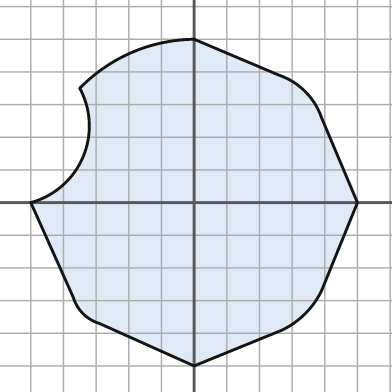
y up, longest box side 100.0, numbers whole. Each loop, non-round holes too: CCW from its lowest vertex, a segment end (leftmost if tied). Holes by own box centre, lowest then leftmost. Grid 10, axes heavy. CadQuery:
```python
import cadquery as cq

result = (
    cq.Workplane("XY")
    .moveTo(0.0, -50.0)
    .lineTo(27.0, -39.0)
    .threePointArc((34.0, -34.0), (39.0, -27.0))
    .lineTo(50.0, 0.0)
    .lineTo(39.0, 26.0)
    .threePointArc((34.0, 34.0), (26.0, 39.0))
    .lineTo(0.0, 50.0)
    .threePointArc((-19.0, 46.0), (-35.0, 35.0))
    .threePointArc((-34.0, 14.0), (-50.0, 0.0))
    .lineTo(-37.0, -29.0)
    .threePointArc((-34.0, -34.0), (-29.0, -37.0))
    .close()
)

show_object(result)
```